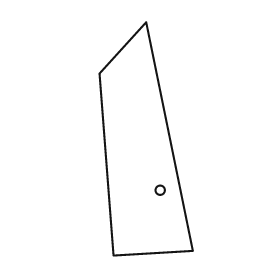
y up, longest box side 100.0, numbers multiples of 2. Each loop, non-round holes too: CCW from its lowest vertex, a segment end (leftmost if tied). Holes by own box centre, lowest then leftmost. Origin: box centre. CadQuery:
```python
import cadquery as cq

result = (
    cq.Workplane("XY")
    .moveTo(-14.0, -50.0)
    .lineTo(20.0, -48.0)
    .lineTo(0.0, 50.0)
    .lineTo(-20.0, 28.0)
    .close()
    .moveTo(6.0, -22.0)
    .circle(2.0)
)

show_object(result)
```